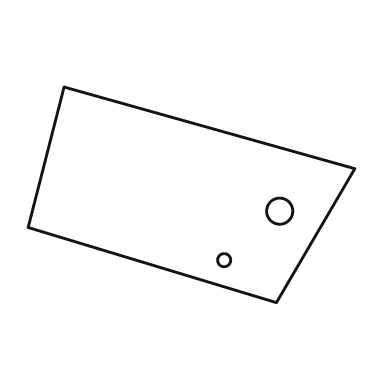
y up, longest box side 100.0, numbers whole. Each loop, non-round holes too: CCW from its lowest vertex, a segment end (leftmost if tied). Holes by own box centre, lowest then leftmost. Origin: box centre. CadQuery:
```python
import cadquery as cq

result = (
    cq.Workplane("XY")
    .moveTo(26.0, -33.0)
    .lineTo(50.0, 8.0)
    .lineTo(-39.0, 33.0)
    .lineTo(-50.0, -10.0)
    .close()
    .moveTo(10.0, -20.0)
    .circle(2.0)
    .moveTo(27.0, -5.0)
    .circle(4.0)
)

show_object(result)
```